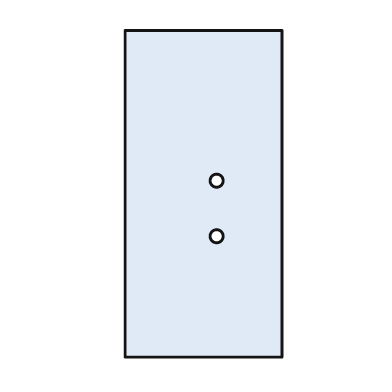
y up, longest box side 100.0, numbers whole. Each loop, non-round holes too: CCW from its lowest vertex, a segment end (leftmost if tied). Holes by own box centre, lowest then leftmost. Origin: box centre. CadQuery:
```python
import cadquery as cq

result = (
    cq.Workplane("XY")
    .moveTo(-24.0, -50.0)
    .lineTo(24.0, -50.0)
    .lineTo(24.0, 50.0)
    .lineTo(-24.0, 50.0)
    .close()
    .moveTo(4.0, -13.0)
    .circle(2.0)
    .moveTo(4.0, 4.0)
    .circle(2.0)
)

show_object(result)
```